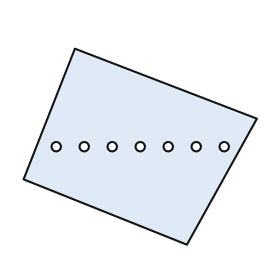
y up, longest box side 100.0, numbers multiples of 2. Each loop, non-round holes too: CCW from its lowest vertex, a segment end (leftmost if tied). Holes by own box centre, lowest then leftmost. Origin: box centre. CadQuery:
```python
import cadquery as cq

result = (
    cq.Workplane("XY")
    .moveTo(20.0, -42.0)
    .lineTo(50.0, 12.0)
    .lineTo(-28.0, 42.0)
    .lineTo(-50.0, -14.0)
    .close()
    .moveTo(-36.0, 0.0)
    .circle(2.0)
    .moveTo(-24.0, 0.0)
    .circle(2.0)
    .moveTo(-12.0, 0.0)
    .circle(2.0)
    .moveTo(0.0, 0.0)
    .circle(2.0)
    .moveTo(12.0, 0.0)
    .circle(2.0)
    .moveTo(24.0, 0.0)
    .circle(2.0)
    .moveTo(36.0, 0.0)
    .circle(2.0)
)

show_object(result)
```